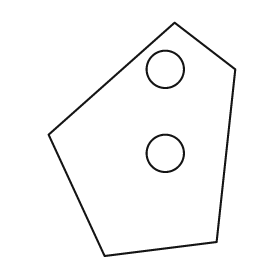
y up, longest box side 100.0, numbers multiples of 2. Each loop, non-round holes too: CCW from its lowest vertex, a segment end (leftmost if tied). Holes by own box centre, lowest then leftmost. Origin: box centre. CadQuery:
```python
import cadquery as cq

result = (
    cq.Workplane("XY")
    .moveTo(-16.0, -50.0)
    .lineTo(32.0, -44.0)
    .lineTo(40.0, 30.0)
    .lineTo(14.0, 50.0)
    .lineTo(-40.0, 2.0)
    .close()
    .moveTo(10.0, -6.0)
    .circle(8.0)
    .moveTo(10.0, 30.0)
    .circle(8.0)
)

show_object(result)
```